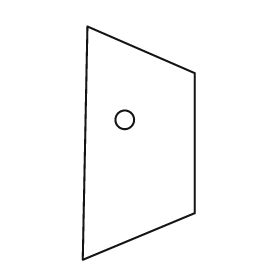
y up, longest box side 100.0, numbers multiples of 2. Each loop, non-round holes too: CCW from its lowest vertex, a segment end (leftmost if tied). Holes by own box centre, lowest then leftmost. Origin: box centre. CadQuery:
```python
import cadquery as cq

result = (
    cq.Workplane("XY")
    .moveTo(-24.0, -50.0)
    .lineTo(24.0, -30.0)
    .lineTo(24.0, 30.0)
    .lineTo(-22.0, 50.0)
    .close()
    .moveTo(-6.0, 10.0)
    .circle(4.0)
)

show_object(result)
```